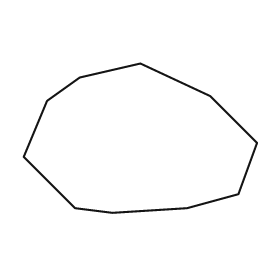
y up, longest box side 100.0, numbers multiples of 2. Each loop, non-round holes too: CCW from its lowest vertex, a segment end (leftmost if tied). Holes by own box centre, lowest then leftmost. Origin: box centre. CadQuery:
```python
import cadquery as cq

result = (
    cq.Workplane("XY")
    .moveTo(-12.0, -32.0)
    .lineTo(20.0, -30.0)
    .lineTo(42.0, -24.0)
    .lineTo(50.0, -2.0)
    .lineTo(30.0, 18.0)
    .lineTo(0.0, 32.0)
    .lineTo(-26.0, 26.0)
    .lineTo(-40.0, 16.0)
    .lineTo(-50.0, -8.0)
    .lineTo(-28.0, -30.0)
    .close()
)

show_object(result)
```